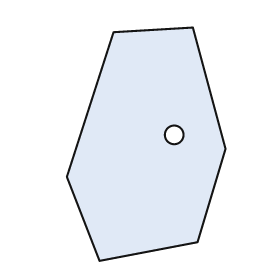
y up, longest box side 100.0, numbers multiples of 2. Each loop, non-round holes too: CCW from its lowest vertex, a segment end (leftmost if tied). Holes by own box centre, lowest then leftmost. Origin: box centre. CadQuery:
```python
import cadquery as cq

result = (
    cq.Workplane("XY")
    .moveTo(-20.0, -50.0)
    .lineTo(22.0, -42.0)
    .lineTo(34.0, -2.0)
    .lineTo(20.0, 50.0)
    .lineTo(-14.0, 48.0)
    .lineTo(-34.0, -14.0)
    .close()
    .moveTo(12.0, 4.0)
    .circle(4.0)
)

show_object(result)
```